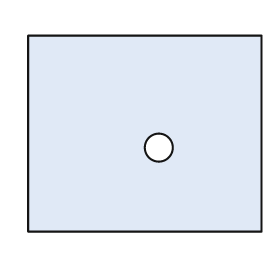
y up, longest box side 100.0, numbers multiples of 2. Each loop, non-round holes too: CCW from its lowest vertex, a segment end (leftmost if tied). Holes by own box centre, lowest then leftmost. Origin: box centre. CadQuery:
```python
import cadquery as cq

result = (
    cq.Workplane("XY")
    .moveTo(-50.0, -42.0)
    .lineTo(50.0, -42.0)
    .lineTo(50.0, 42.0)
    .lineTo(-50.0, 42.0)
    .close()
    .moveTo(6.0, -6.0)
    .circle(6.0)
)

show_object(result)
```